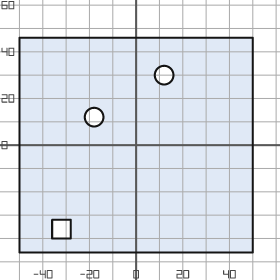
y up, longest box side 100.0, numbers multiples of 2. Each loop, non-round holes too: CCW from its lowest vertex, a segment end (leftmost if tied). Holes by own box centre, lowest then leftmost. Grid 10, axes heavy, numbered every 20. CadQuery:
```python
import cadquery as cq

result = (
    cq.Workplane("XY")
    .moveTo(-50.0, -46.0)
    .lineTo(50.0, -46.0)
    .lineTo(50.0, 46.0)
    .lineTo(-50.0, 46.0)
    .close()
    .moveTo(-36.0, -40.0)
    .lineTo(-28.0, -40.0)
    .lineTo(-28.0, -32.0)
    .lineTo(-36.0, -32.0)
    .close()
    .moveTo(-18.0, 12.0)
    .circle(4.0)
    .moveTo(12.0, 30.0)
    .circle(4.0)
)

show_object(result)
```